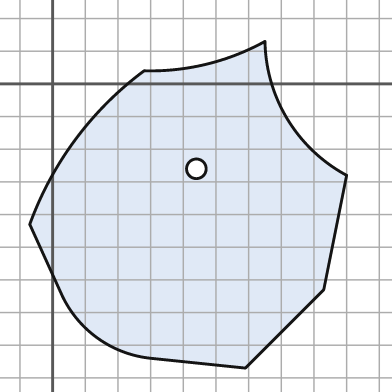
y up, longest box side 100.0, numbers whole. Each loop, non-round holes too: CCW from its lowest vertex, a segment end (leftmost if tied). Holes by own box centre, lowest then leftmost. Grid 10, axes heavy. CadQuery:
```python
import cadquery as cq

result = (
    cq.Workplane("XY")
    .moveTo(59.0, -87.0)
    .lineTo(83.0, -63.0)
    .lineTo(90.0, -28.0)
    .threePointArc((72.0, -11.0), (65.0, 13.0))
    .threePointArc((47.0, 6.0), (28.0, 4.0))
    .threePointArc((7.0, -17.0), (-7.0, -43.0))
    .lineTo(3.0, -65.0)
    .threePointArc((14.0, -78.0), (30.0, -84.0))
    .close()
    .moveTo(44.0, -26.0)
    .circle(3.0)
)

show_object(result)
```